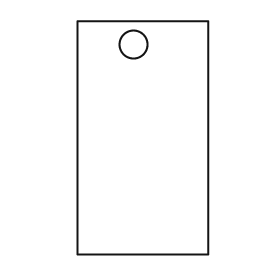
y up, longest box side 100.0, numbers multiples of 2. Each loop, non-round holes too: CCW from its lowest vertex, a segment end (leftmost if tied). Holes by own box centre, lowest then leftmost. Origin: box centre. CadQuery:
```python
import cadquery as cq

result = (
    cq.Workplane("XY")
    .moveTo(-28.0, -50.0)
    .lineTo(28.0, -50.0)
    .lineTo(28.0, 50.0)
    .lineTo(-28.0, 50.0)
    .close()
    .moveTo(-4.0, 40.0)
    .circle(6.0)
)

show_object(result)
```